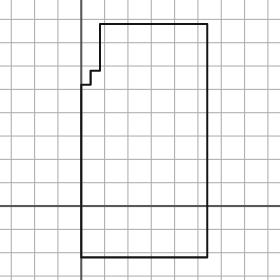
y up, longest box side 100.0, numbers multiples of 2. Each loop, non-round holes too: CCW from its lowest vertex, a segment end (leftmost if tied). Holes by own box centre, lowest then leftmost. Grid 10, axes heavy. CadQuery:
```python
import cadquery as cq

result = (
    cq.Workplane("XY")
    .moveTo(0.0, -22.0)
    .lineTo(54.0, -22.0)
    .lineTo(54.0, 78.0)
    .lineTo(8.0, 78.0)
    .lineTo(8.0, 58.0)
    .lineTo(4.0, 58.0)
    .lineTo(4.0, 52.0)
    .lineTo(0.0, 52.0)
    .close()
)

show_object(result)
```